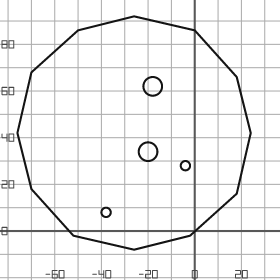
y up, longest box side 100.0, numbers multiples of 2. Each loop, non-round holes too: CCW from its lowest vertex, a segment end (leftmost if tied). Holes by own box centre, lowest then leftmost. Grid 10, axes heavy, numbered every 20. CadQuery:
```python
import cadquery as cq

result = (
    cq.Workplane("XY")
    .moveTo(-26.0, -8.0)
    .lineTo(-2.0, -2.0)
    .lineTo(18.0, 16.0)
    .lineTo(24.0, 42.0)
    .lineTo(18.0, 66.0)
    .lineTo(0.0, 86.0)
    .lineTo(-26.0, 92.0)
    .lineTo(-50.0, 86.0)
    .lineTo(-70.0, 68.0)
    .lineTo(-76.0, 42.0)
    .lineTo(-70.0, 18.0)
    .lineTo(-52.0, -2.0)
    .close()
    .moveTo(-38.0, 8.0)
    .circle(2.0)
    .moveTo(-4.0, 28.0)
    .circle(2.0)
    .moveTo(-20.0, 34.0)
    .circle(4.0)
    .moveTo(-18.0, 62.0)
    .circle(4.0)
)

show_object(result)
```